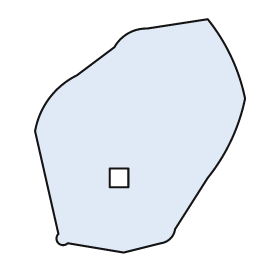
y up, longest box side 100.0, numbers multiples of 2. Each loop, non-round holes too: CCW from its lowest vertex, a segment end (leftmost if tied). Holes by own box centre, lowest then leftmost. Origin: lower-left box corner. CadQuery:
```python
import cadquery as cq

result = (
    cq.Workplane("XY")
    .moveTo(38.0, 0.0)
    .lineTo(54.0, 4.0)
    .threePointArc((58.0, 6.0), (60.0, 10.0))
    .lineTo(74.0, 32.0)
    .threePointArc((84.0, 48.0), (90.0, 66.0))
    .threePointArc((84.0, 84.0), (74.0, 100.0))
    .lineTo(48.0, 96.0)
    .threePointArc((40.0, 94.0), (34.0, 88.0))
    .lineTo(18.0, 76.0)
    .threePointArc((6.0, 66.0), (0.0, 52.0))
    .lineTo(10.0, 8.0)
    .threePointArc((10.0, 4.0), (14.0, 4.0))
    .close()
    .moveTo(32.0, 28.0)
    .lineTo(40.0, 28.0)
    .lineTo(40.0, 36.0)
    .lineTo(32.0, 36.0)
    .close()
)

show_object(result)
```